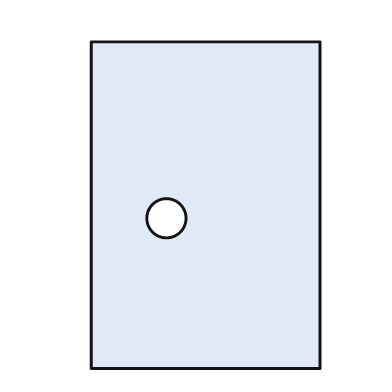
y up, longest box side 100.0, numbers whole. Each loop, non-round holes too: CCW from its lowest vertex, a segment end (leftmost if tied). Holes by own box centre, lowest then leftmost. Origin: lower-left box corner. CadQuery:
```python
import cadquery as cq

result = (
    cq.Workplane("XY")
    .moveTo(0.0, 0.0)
    .lineTo(70.0, 0.0)
    .lineTo(70.0, 100.0)
    .lineTo(0.0, 100.0)
    .close()
    .moveTo(23.0, 46.0)
    .circle(6.0)
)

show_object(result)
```